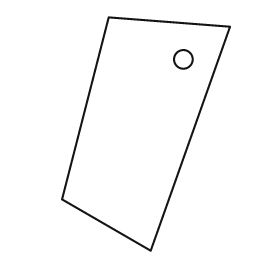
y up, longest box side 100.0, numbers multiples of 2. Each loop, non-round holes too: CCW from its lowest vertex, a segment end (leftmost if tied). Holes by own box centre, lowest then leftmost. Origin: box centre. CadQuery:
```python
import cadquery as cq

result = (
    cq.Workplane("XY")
    .moveTo(2.0, -50.0)
    .lineTo(36.0, 46.0)
    .lineTo(-16.0, 50.0)
    .lineTo(-36.0, -28.0)
    .close()
    .moveTo(16.0, 32.0)
    .circle(4.0)
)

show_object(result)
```